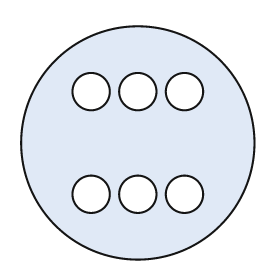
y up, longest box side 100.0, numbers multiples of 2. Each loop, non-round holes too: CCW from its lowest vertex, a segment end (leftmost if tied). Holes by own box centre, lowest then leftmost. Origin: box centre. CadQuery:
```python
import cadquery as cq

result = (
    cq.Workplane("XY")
    .moveTo(0.0, 0.0)
    .circle(50.0)
    .moveTo(-20.0, -22.0)
    .circle(8.0)
    .moveTo(0.0, -22.0)
    .circle(8.0)
    .moveTo(20.0, -22.0)
    .circle(8.0)
    .moveTo(-20.0, 22.0)
    .circle(8.0)
    .moveTo(0.0, 22.0)
    .circle(8.0)
    .moveTo(20.0, 22.0)
    .circle(8.0)
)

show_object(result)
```